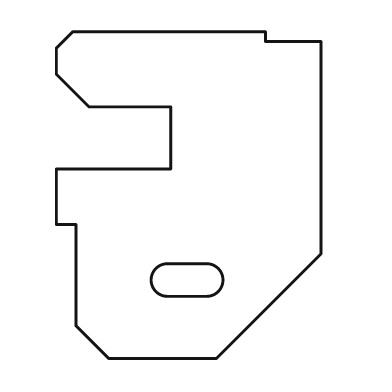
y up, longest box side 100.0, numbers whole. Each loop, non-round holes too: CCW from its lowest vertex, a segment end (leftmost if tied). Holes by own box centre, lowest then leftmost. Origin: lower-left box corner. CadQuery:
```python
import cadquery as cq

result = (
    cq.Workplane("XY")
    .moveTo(16.0, 0.0)
    .lineTo(49.0, 0.0)
    .lineTo(81.0, 32.0)
    .lineTo(81.0, 97.0)
    .lineTo(64.0, 97.0)
    .lineTo(64.0, 100.0)
    .lineTo(5.0, 100.0)
    .lineTo(0.0, 95.0)
    .lineTo(0.0, 87.0)
    .lineTo(10.0, 77.0)
    .lineTo(35.0, 77.0)
    .lineTo(35.0, 58.0)
    .lineTo(0.0, 58.0)
    .lineTo(0.0, 41.0)
    .lineTo(6.0, 41.0)
    .lineTo(6.0, 10.0)
    .close()
    .moveTo(34.0, 19.0)
    .lineTo(46.0, 19.0)
    .threePointArc((51.0, 24.0), (46.0, 29.0))
    .lineTo(34.0, 29.0)
    .threePointArc((29.0, 24.0), (34.0, 19.0))
    .close()
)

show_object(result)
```